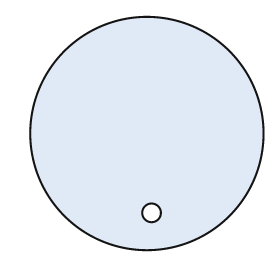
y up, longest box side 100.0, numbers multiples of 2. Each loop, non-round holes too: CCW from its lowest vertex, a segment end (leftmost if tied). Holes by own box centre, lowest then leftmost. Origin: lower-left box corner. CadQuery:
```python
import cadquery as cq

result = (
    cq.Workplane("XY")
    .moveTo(50.0, 50.0)
    .circle(50.0)
    .moveTo(52.0, 16.0)
    .circle(4.0)
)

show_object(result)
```